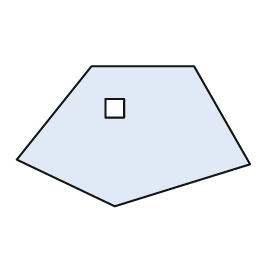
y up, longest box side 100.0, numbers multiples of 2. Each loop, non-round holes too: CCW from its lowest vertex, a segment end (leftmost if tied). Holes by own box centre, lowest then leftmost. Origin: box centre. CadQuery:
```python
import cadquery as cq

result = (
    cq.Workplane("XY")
    .moveTo(-8.0, -30.0)
    .lineTo(50.0, -12.0)
    .lineTo(26.0, 30.0)
    .lineTo(-18.0, 30.0)
    .lineTo(-50.0, -10.0)
    .close()
    .moveTo(-12.0, 8.0)
    .lineTo(-4.0, 8.0)
    .lineTo(-4.0, 16.0)
    .lineTo(-12.0, 16.0)
    .close()
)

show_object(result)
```